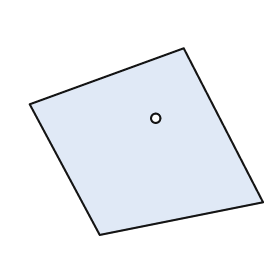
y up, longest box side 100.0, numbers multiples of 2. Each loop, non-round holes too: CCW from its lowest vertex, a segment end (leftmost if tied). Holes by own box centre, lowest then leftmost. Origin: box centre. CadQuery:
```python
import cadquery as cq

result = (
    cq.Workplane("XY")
    .moveTo(-20.0, -40.0)
    .lineTo(50.0, -26.0)
    .lineTo(16.0, 40.0)
    .lineTo(-50.0, 16.0)
    .close()
    .moveTo(4.0, 10.0)
    .circle(2.0)
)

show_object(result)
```